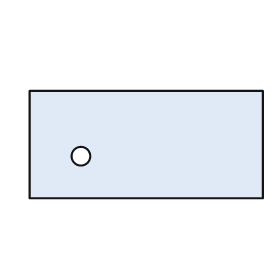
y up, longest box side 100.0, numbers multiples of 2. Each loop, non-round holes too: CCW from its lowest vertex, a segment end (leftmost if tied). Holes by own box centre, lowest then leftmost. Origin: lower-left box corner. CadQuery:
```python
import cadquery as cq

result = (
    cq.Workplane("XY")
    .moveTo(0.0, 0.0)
    .lineTo(100.0, 0.0)
    .lineTo(100.0, 46.0)
    .lineTo(0.0, 46.0)
    .close()
    .moveTo(22.0, 18.0)
    .circle(4.0)
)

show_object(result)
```